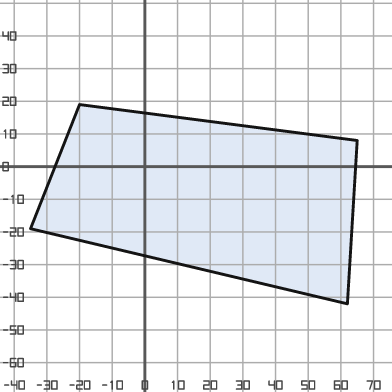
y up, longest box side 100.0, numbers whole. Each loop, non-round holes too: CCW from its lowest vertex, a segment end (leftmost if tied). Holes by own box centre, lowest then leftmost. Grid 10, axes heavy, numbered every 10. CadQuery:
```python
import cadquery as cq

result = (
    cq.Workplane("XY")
    .moveTo(62.0, -42.0)
    .lineTo(65.0, 8.0)
    .lineTo(-20.0, 19.0)
    .lineTo(-35.0, -19.0)
    .close()
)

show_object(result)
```